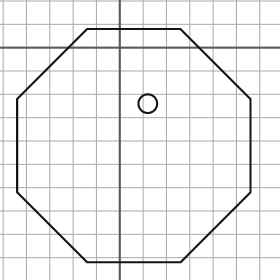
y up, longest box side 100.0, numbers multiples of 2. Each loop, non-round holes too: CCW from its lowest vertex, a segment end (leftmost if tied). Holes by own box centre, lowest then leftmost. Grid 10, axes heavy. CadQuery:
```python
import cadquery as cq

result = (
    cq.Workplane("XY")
    .moveTo(-14.0, -92.0)
    .lineTo(26.0, -92.0)
    .lineTo(56.0, -62.0)
    .lineTo(56.0, -22.0)
    .lineTo(26.0, 8.0)
    .lineTo(-14.0, 8.0)
    .lineTo(-44.0, -22.0)
    .lineTo(-44.0, -62.0)
    .close()
    .moveTo(12.0, -24.0)
    .circle(4.0)
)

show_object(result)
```